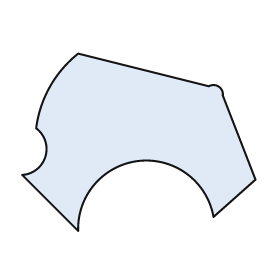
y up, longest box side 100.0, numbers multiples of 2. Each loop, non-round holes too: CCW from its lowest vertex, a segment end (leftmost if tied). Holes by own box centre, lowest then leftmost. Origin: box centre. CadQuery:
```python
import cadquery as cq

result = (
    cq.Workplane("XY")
    .moveTo(-26.0, -38.0)
    .threePointArc((0.0, -8.0), (32.0, -32.0))
    .lineTo(50.0, -16.0)
    .lineTo(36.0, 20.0)
    .threePointArc((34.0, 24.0), (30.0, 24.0))
    .lineTo(-26.0, 38.0)
    .threePointArc((-38.0, 24.0), (-44.0, 6.0))
    .threePointArc((-40.0, -6.0), (-50.0, -14.0))
    .close()
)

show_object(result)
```